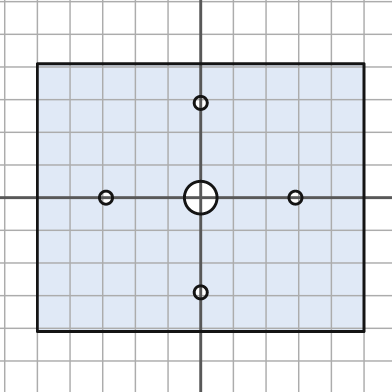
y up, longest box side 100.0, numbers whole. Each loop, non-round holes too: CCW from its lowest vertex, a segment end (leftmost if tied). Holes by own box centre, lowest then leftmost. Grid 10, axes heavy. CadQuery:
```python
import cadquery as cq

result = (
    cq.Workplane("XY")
    .moveTo(-50.0, -41.0)
    .lineTo(50.0, -41.0)
    .lineTo(50.0, 41.0)
    .lineTo(-50.0, 41.0)
    .close()
    .moveTo(0.0, -29.0)
    .circle(2.0)
    .moveTo(-29.0, 0.0)
    .circle(2.0)
    .moveTo(0.0, 0.0)
    .circle(5.0)
    .moveTo(29.0, 0.0)
    .circle(2.0)
    .moveTo(0.0, 29.0)
    .circle(2.0)
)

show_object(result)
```